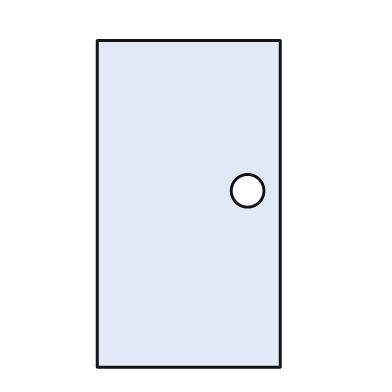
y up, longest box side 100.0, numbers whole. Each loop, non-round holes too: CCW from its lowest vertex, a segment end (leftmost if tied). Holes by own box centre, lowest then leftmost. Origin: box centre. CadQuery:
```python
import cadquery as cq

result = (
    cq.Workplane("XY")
    .moveTo(-28.0, -50.0)
    .lineTo(28.0, -50.0)
    .lineTo(28.0, 50.0)
    .lineTo(-28.0, 50.0)
    .close()
    .moveTo(18.0, 4.0)
    .circle(5.0)
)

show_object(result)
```